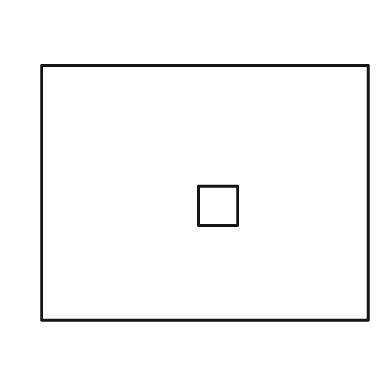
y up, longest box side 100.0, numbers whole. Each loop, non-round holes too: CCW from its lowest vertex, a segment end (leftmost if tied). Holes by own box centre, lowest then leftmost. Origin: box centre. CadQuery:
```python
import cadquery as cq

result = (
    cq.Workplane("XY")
    .moveTo(-50.0, -39.0)
    .lineTo(50.0, -39.0)
    .lineTo(50.0, 39.0)
    .lineTo(-50.0, 39.0)
    .close()
    .moveTo(-2.0, -10.0)
    .lineTo(10.0, -10.0)
    .lineTo(10.0, 2.0)
    .lineTo(-2.0, 2.0)
    .close()
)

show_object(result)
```